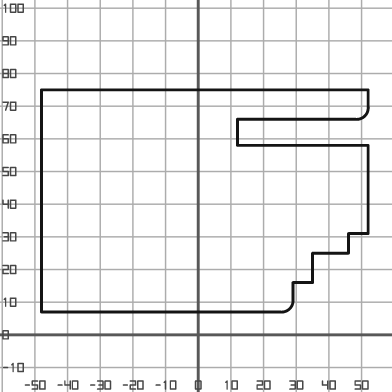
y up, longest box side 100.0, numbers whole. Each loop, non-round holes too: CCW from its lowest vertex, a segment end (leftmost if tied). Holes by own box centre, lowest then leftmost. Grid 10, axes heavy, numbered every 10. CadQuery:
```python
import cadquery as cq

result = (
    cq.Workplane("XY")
    .moveTo(-48.0, 7.0)
    .lineTo(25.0, 7.0)
    .threePointArc((28.0, 8.0), (29.0, 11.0))
    .lineTo(29.0, 16.0)
    .lineTo(35.0, 16.0)
    .lineTo(35.0, 25.0)
    .lineTo(46.0, 25.0)
    .lineTo(46.0, 31.0)
    .lineTo(52.0, 31.0)
    .lineTo(52.0, 58.0)
    .lineTo(12.0, 58.0)
    .lineTo(12.0, 66.0)
    .lineTo(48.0, 66.0)
    .threePointArc((51.0, 67.0), (52.0, 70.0))
    .lineTo(52.0, 75.0)
    .lineTo(-48.0, 75.0)
    .close()
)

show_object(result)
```